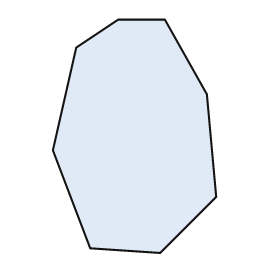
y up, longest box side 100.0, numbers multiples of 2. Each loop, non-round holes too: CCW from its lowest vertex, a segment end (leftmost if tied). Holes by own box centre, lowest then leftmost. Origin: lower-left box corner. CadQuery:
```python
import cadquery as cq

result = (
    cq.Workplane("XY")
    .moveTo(46.0, 0.0)
    .lineTo(70.0, 24.0)
    .lineTo(66.0, 68.0)
    .lineTo(48.0, 100.0)
    .lineTo(28.0, 100.0)
    .lineTo(10.0, 88.0)
    .lineTo(0.0, 44.0)
    .lineTo(16.0, 2.0)
    .close()
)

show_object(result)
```